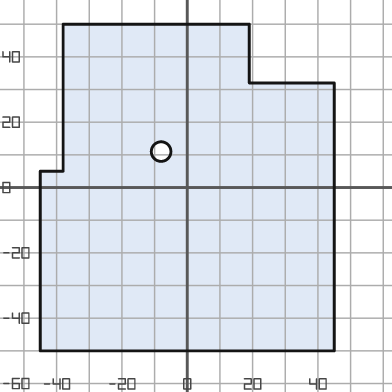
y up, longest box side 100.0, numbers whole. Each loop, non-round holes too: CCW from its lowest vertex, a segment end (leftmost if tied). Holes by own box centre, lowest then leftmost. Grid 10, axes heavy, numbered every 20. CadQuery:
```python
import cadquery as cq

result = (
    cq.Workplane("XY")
    .moveTo(-45.0, -50.0)
    .lineTo(45.0, -50.0)
    .lineTo(45.0, 32.0)
    .lineTo(19.0, 32.0)
    .lineTo(19.0, 50.0)
    .lineTo(-38.0, 50.0)
    .lineTo(-38.0, 5.0)
    .lineTo(-45.0, 5.0)
    .close()
    .moveTo(-8.0, 11.0)
    .circle(3.0)
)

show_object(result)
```